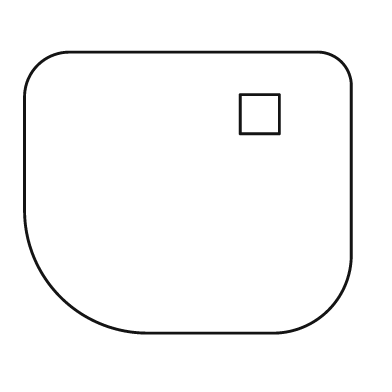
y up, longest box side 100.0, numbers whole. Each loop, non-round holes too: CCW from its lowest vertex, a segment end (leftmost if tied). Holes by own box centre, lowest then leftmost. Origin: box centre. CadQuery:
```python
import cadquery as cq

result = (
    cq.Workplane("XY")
    .moveTo(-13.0, -43.0)
    .lineTo(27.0, -43.0)
    .threePointArc((43.0, -36.0), (50.0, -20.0))
    .lineTo(50.0, 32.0)
    .threePointArc((47.0, 40.0), (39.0, 43.0))
    .lineTo(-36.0, 43.0)
    .threePointArc((-46.0, 39.0), (-50.0, 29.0))
    .lineTo(-50.0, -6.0)
    .threePointArc((-39.0, -32.0), (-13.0, -43.0))
    .close()
    .moveTo(16.0, 18.0)
    .lineTo(28.0, 18.0)
    .lineTo(28.0, 30.0)
    .lineTo(16.0, 30.0)
    .close()
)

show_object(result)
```